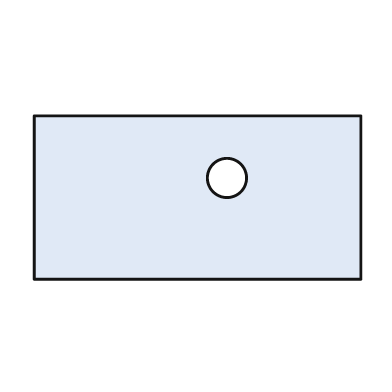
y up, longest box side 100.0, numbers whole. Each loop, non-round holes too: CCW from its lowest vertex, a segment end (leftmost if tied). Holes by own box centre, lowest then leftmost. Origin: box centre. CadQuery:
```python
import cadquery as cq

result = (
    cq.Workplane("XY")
    .moveTo(-50.0, -25.0)
    .lineTo(50.0, -25.0)
    .lineTo(50.0, 25.0)
    .lineTo(-50.0, 25.0)
    .close()
    .moveTo(9.0, 6.0)
    .circle(6.0)
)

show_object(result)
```